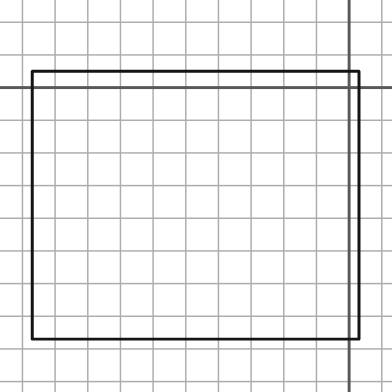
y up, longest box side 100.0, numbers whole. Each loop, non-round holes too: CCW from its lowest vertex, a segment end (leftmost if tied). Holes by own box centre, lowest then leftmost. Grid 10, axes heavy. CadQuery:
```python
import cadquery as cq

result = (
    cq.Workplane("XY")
    .moveTo(-97.0, -77.0)
    .lineTo(3.0, -77.0)
    .lineTo(3.0, 5.0)
    .lineTo(-97.0, 5.0)
    .close()
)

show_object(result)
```